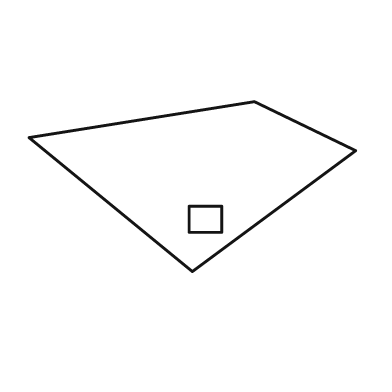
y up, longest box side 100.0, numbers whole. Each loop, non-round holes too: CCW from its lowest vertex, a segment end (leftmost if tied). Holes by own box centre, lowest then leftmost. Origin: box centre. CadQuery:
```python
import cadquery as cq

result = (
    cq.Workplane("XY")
    .moveTo(0.0, -26.0)
    .lineTo(50.0, 11.0)
    .lineTo(19.0, 26.0)
    .lineTo(-50.0, 15.0)
    .close()
    .moveTo(-1.0, -14.0)
    .lineTo(9.0, -14.0)
    .lineTo(9.0, -6.0)
    .lineTo(-1.0, -6.0)
    .close()
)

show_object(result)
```